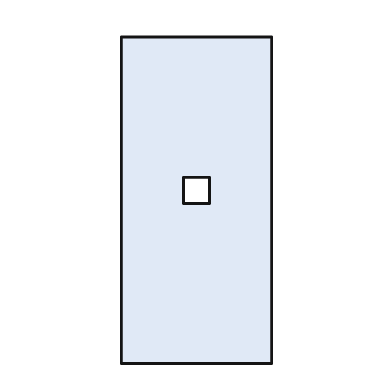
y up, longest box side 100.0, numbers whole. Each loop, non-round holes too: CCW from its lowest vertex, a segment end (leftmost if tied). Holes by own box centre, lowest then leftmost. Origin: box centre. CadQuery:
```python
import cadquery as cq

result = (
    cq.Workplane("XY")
    .moveTo(-23.0, -50.0)
    .lineTo(23.0, -50.0)
    .lineTo(23.0, 50.0)
    .lineTo(-23.0, 50.0)
    .close()
    .moveTo(-4.0, -1.0)
    .lineTo(4.0, -1.0)
    .lineTo(4.0, 7.0)
    .lineTo(-4.0, 7.0)
    .close()
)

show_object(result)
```